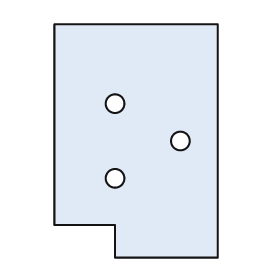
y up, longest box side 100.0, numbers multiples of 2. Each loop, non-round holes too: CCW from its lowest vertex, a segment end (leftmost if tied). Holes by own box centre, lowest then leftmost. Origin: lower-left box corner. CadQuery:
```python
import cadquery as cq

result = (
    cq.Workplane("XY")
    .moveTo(26.0, 0.0)
    .lineTo(70.0, 0.0)
    .lineTo(70.0, 100.0)
    .lineTo(0.0, 100.0)
    .lineTo(0.0, 14.0)
    .lineTo(26.0, 14.0)
    .close()
    .moveTo(26.0, 34.0)
    .circle(4.0)
    .moveTo(54.0, 50.0)
    .circle(4.0)
    .moveTo(26.0, 66.0)
    .circle(4.0)
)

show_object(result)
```